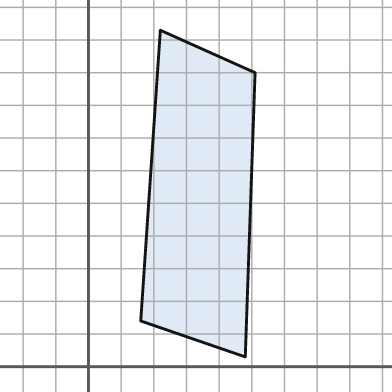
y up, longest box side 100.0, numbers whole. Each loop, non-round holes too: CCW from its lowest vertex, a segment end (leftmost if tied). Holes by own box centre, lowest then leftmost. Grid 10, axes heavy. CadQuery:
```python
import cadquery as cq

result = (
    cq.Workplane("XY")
    .moveTo(48.0, 3.0)
    .lineTo(51.0, 90.0)
    .lineTo(22.0, 103.0)
    .lineTo(16.0, 14.0)
    .close()
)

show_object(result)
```